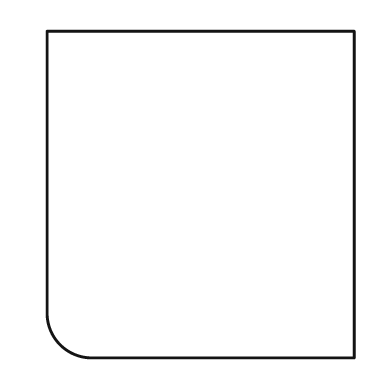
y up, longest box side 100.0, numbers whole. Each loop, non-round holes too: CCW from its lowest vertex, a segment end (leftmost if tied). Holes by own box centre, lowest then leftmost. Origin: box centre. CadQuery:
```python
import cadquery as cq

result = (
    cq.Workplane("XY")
    .moveTo(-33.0, -50.0)
    .lineTo(47.0, -50.0)
    .lineTo(47.0, 50.0)
    .lineTo(-47.0, 50.0)
    .lineTo(-47.0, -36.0)
    .threePointArc((-43.0, -46.0), (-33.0, -50.0))
    .close()
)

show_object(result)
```